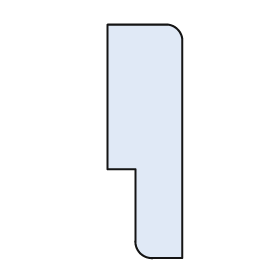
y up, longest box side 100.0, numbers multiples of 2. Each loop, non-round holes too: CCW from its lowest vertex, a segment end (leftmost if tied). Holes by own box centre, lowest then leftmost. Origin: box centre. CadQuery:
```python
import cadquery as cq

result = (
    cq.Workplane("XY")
    .moveTo(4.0, -50.0)
    .lineTo(16.0, -50.0)
    .lineTo(16.0, 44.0)
    .threePointArc((14.0, 48.0), (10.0, 50.0))
    .lineTo(-16.0, 50.0)
    .lineTo(-16.0, -12.0)
    .lineTo(-4.0, -12.0)
    .lineTo(-4.0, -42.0)
    .threePointArc((-2.0, -48.0), (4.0, -50.0))
    .close()
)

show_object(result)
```